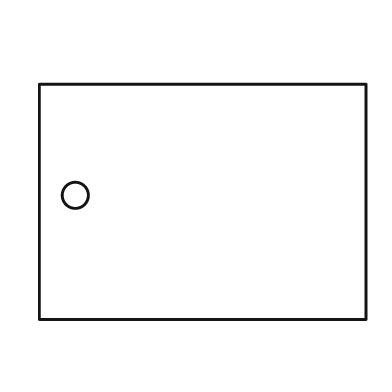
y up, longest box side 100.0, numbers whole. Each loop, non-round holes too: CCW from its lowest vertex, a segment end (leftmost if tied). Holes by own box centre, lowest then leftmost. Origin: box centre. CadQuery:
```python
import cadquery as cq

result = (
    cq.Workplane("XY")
    .moveTo(-50.0, -36.0)
    .lineTo(50.0, -36.0)
    .lineTo(50.0, 36.0)
    .lineTo(-50.0, 36.0)
    .close()
    .moveTo(-39.0, 2.0)
    .circle(4.0)
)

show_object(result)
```